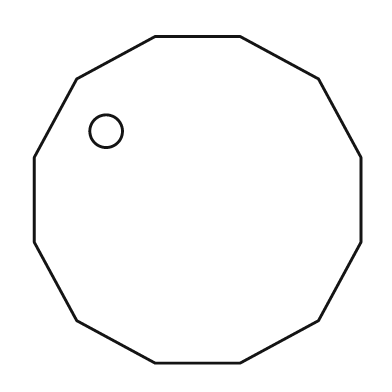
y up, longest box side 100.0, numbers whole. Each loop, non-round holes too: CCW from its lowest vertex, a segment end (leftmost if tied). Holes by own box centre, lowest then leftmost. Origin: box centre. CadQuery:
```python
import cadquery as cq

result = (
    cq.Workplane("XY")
    .moveTo(-13.0, -50.0)
    .lineTo(13.0, -50.0)
    .lineTo(37.0, -37.0)
    .lineTo(50.0, -13.0)
    .lineTo(50.0, 13.0)
    .lineTo(37.0, 37.0)
    .lineTo(13.0, 50.0)
    .lineTo(-13.0, 50.0)
    .lineTo(-37.0, 37.0)
    .lineTo(-50.0, 13.0)
    .lineTo(-50.0, -13.0)
    .lineTo(-37.0, -37.0)
    .close()
    .moveTo(-28.0, 21.0)
    .circle(5.0)
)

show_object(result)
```